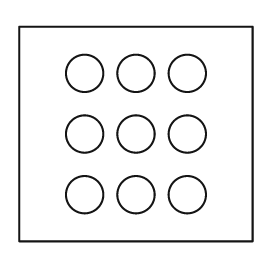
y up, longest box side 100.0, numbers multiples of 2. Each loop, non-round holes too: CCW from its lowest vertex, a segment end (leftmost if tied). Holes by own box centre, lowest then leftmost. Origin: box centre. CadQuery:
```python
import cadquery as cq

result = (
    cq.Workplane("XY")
    .moveTo(-50.0, -46.0)
    .lineTo(50.0, -46.0)
    .lineTo(50.0, 46.0)
    .lineTo(-50.0, 46.0)
    .close()
    .moveTo(-22.0, -26.0)
    .circle(8.0)
    .moveTo(0.0, -26.0)
    .circle(8.0)
    .moveTo(22.0, -26.0)
    .circle(8.0)
    .moveTo(-22.0, 0.0)
    .circle(8.0)
    .moveTo(0.0, 0.0)
    .circle(8.0)
    .moveTo(22.0, 0.0)
    .circle(8.0)
    .moveTo(-22.0, 26.0)
    .circle(8.0)
    .moveTo(0.0, 26.0)
    .circle(8.0)
    .moveTo(22.0, 26.0)
    .circle(8.0)
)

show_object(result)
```